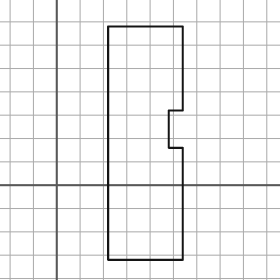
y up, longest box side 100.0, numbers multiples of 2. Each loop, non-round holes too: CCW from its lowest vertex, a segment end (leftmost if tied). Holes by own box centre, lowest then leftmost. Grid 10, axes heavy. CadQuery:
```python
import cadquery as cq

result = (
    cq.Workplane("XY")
    .moveTo(22.0, -32.0)
    .lineTo(54.0, -32.0)
    .lineTo(54.0, 16.0)
    .lineTo(48.0, 16.0)
    .lineTo(48.0, 32.0)
    .lineTo(54.0, 32.0)
    .lineTo(54.0, 68.0)
    .lineTo(22.0, 68.0)
    .close()
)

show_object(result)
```